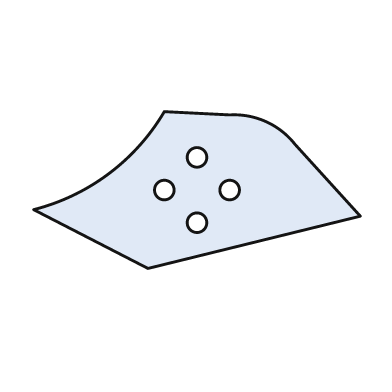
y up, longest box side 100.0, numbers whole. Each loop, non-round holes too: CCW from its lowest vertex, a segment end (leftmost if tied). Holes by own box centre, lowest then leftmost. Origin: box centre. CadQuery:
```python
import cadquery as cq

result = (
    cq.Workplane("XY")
    .moveTo(-15.0, -24.0)
    .lineTo(50.0, -8.0)
    .lineTo(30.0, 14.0)
    .threePointArc((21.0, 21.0), (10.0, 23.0))
    .lineTo(-10.0, 24.0)
    .threePointArc((-27.0, 5.0), (-50.0, -6.0))
    .close()
    .moveTo(0.0, -10.0)
    .circle(3.0)
    .moveTo(-10.0, 0.0)
    .circle(3.0)
    .moveTo(10.0, 0.0)
    .circle(3.0)
    .moveTo(0.0, 10.0)
    .circle(3.0)
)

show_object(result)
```